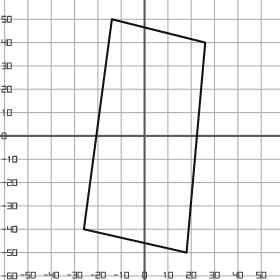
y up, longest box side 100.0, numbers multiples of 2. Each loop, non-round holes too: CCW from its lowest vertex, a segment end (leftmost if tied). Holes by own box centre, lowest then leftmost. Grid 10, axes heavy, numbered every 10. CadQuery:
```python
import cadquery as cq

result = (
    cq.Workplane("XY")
    .moveTo(18.0, -50.0)
    .lineTo(26.0, 40.0)
    .lineTo(-14.0, 50.0)
    .lineTo(-26.0, -40.0)
    .close()
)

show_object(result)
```